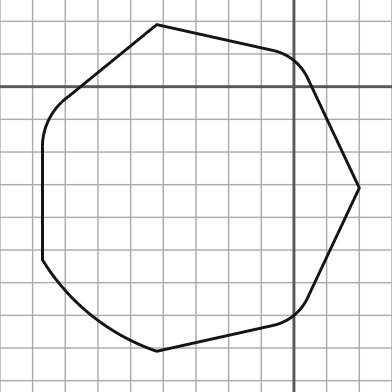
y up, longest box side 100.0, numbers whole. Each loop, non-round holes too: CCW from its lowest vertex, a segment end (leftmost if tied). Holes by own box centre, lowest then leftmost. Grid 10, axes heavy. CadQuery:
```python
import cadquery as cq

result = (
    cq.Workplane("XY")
    .moveTo(-42.0, -81.0)
    .lineTo(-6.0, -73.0)
    .threePointArc((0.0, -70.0), (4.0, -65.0))
    .lineTo(20.0, -31.0)
    .lineTo(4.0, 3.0)
    .threePointArc((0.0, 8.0), (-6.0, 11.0))
    .lineTo(-42.0, 19.0)
    .lineTo(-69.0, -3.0)
    .threePointArc((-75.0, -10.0), (-77.0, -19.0))
    .lineTo(-77.0, -53.0)
    .threePointArc((-62.0, -70.0), (-42.0, -81.0))
    .close()
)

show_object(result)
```